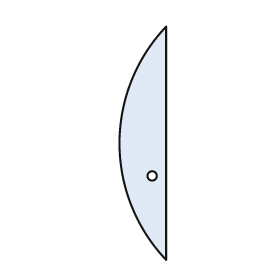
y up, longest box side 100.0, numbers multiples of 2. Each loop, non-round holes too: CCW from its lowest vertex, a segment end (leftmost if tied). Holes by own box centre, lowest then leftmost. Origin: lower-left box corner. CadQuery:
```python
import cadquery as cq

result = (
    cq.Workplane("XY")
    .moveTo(20.0, 0.0)
    .lineTo(20.0, 100.0)
    .threePointArc((0.0, 50.0), (20.0, 0.0))
    .close()
    .moveTo(14.0, 36.0)
    .circle(2.0)
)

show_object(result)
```